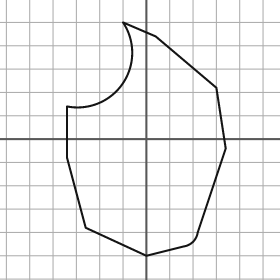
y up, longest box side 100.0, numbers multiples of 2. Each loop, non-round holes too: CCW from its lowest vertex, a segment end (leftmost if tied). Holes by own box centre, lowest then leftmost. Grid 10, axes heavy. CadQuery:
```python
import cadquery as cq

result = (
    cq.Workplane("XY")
    .moveTo(0.0, -50.0)
    .lineTo(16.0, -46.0)
    .threePointArc((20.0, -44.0), (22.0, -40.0))
    .lineTo(34.0, -4.0)
    .lineTo(30.0, 22.0)
    .lineTo(4.0, 44.0)
    .lineTo(-10.0, 50.0)
    .threePointArc((-10.0, 24.0), (-34.0, 14.0))
    .lineTo(-34.0, -8.0)
    .lineTo(-26.0, -38.0)
    .close()
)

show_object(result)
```